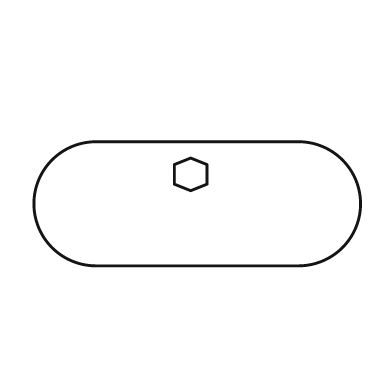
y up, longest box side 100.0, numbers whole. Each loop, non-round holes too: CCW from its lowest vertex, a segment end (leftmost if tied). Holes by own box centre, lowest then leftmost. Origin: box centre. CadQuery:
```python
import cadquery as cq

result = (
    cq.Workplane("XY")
    .moveTo(-31.0, -19.0)
    .lineTo(31.0, -19.0)
    .threePointArc((50.0, 0.0), (31.0, 19.0))
    .lineTo(-31.0, 19.0)
    .threePointArc((-50.0, 0.0), (-31.0, -19.0))
    .close()
    .moveTo(-2.0, 4.0)
    .lineTo(3.0, 6.0)
    .lineTo(3.0, 12.0)
    .lineTo(-2.0, 14.0)
    .lineTo(-7.0, 12.0)
    .lineTo(-7.0, 6.0)
    .close()
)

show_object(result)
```